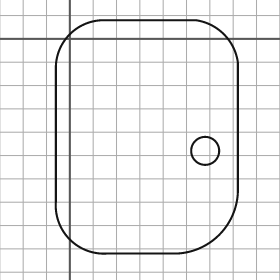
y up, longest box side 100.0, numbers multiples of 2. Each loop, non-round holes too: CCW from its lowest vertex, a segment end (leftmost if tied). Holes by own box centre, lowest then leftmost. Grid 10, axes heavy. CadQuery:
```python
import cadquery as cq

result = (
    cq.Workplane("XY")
    .moveTo(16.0, -92.0)
    .lineTo(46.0, -92.0)
    .threePointArc((64.0, -84.0), (72.0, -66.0))
    .lineTo(72.0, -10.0)
    .threePointArc((66.0, 2.0), (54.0, 8.0))
    .lineTo(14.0, 8.0)
    .threePointArc((0.0, 2.0), (-6.0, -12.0))
    .lineTo(-6.0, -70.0)
    .threePointArc((0.0, -86.0), (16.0, -92.0))
    .close()
    .moveTo(58.0, -48.0)
    .circle(6.0)
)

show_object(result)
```